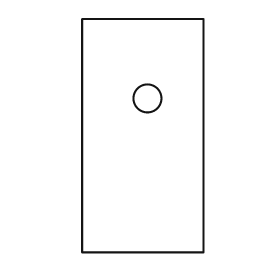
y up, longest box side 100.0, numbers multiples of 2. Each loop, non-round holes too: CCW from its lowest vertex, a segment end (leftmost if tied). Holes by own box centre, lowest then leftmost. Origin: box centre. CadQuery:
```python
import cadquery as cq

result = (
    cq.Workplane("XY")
    .moveTo(-26.0, -50.0)
    .lineTo(26.0, -50.0)
    .lineTo(26.0, 50.0)
    .lineTo(-26.0, 50.0)
    .close()
    .moveTo(2.0, 16.0)
    .circle(6.0)
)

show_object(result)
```